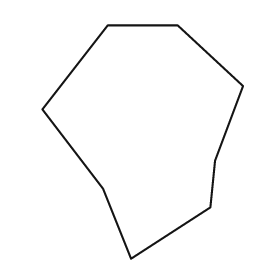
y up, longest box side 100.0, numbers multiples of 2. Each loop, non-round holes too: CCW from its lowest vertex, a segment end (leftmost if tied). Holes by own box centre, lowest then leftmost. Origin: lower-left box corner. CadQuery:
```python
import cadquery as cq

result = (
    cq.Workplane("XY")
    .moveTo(38.0, 0.0)
    .lineTo(72.0, 22.0)
    .lineTo(74.0, 42.0)
    .lineTo(86.0, 74.0)
    .lineTo(58.0, 100.0)
    .lineTo(28.0, 100.0)
    .lineTo(0.0, 64.0)
    .lineTo(26.0, 30.0)
    .close()
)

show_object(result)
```